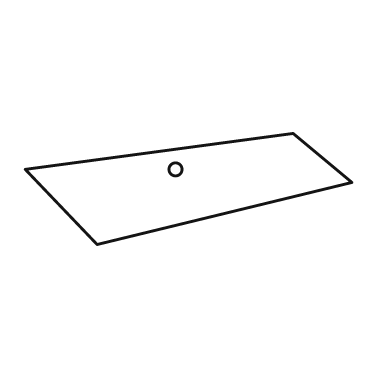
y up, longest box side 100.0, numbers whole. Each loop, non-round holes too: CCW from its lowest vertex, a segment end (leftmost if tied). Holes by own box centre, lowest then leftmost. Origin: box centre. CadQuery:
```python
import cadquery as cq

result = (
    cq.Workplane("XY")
    .moveTo(-28.0, -17.0)
    .lineTo(50.0, 2.0)
    .lineTo(32.0, 17.0)
    .lineTo(-50.0, 6.0)
    .close()
    .moveTo(-4.0, 6.0)
    .circle(2.0)
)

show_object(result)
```